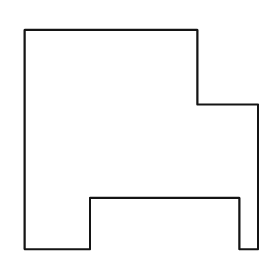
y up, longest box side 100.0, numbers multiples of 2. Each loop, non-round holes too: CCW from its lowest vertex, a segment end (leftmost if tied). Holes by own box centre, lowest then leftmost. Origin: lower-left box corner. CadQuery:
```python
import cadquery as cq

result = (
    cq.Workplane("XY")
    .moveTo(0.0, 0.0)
    .lineTo(28.0, 0.0)
    .lineTo(28.0, 22.0)
    .lineTo(92.0, 22.0)
    .lineTo(92.0, 0.0)
    .lineTo(100.0, 0.0)
    .lineTo(100.0, 62.0)
    .lineTo(74.0, 62.0)
    .lineTo(74.0, 94.0)
    .lineTo(0.0, 94.0)
    .close()
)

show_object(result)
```